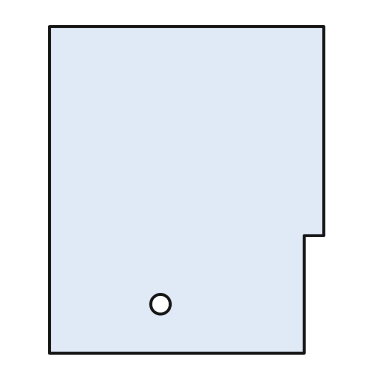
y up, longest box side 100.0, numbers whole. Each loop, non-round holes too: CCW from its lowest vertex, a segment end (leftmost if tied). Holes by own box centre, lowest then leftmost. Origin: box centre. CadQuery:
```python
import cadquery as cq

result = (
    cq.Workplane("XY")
    .moveTo(-42.0, -50.0)
    .lineTo(36.0, -50.0)
    .lineTo(36.0, -14.0)
    .lineTo(42.0, -14.0)
    .lineTo(42.0, 50.0)
    .lineTo(-42.0, 50.0)
    .close()
    .moveTo(-8.0, -35.0)
    .circle(3.0)
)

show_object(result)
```